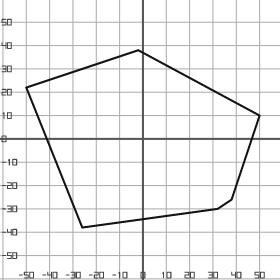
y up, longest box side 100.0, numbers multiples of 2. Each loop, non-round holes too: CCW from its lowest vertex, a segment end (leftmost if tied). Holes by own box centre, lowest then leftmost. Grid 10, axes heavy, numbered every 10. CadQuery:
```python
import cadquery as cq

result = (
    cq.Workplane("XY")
    .moveTo(-26.0, -38.0)
    .lineTo(32.0, -30.0)
    .lineTo(38.0, -26.0)
    .lineTo(50.0, 10.0)
    .lineTo(-2.0, 38.0)
    .lineTo(-50.0, 22.0)
    .close()
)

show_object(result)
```